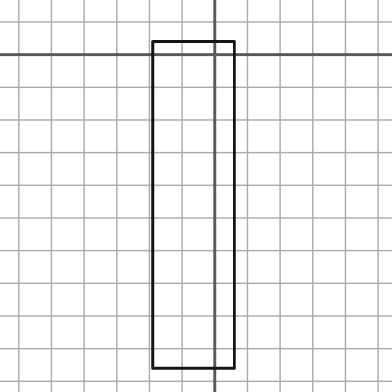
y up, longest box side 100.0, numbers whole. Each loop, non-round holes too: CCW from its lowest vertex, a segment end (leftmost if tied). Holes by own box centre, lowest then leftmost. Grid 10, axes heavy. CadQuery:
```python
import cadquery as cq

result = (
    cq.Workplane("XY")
    .moveTo(-19.0, -96.0)
    .lineTo(6.0, -96.0)
    .lineTo(6.0, 4.0)
    .lineTo(-19.0, 4.0)
    .close()
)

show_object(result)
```